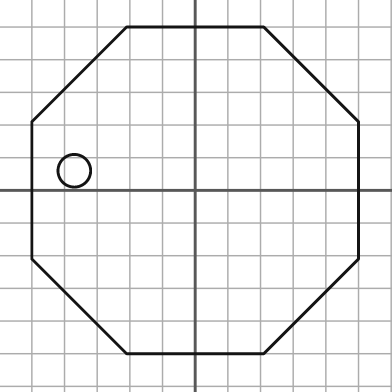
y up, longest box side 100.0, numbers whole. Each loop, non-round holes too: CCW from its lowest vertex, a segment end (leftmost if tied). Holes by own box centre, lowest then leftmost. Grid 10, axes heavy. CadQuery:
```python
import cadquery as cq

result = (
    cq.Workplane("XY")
    .moveTo(-21.0, -50.0)
    .lineTo(21.0, -50.0)
    .lineTo(50.0, -21.0)
    .lineTo(50.0, 21.0)
    .lineTo(21.0, 50.0)
    .lineTo(-21.0, 50.0)
    .lineTo(-50.0, 21.0)
    .lineTo(-50.0, -21.0)
    .close()
    .moveTo(-37.0, 6.0)
    .circle(5.0)
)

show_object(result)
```